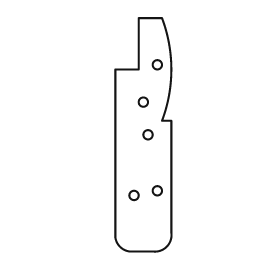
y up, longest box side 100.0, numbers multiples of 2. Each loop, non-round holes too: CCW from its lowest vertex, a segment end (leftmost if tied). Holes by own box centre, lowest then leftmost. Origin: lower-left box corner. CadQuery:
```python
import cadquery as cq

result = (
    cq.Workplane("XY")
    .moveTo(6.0, 0.0)
    .lineTo(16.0, 0.0)
    .threePointArc((22.0, 2.0), (24.0, 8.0))
    .lineTo(24.0, 56.0)
    .lineTo(20.0, 56.0)
    .threePointArc((24.0, 78.0), (20.0, 100.0))
    .lineTo(10.0, 100.0)
    .lineTo(10.0, 78.0)
    .lineTo(0.0, 78.0)
    .lineTo(0.0, 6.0)
    .threePointArc((2.0, 2.0), (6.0, 0.0))
    .close()
    .moveTo(8.0, 24.0)
    .circle(2.0)
    .moveTo(18.0, 26.0)
    .circle(2.0)
    .moveTo(14.0, 50.0)
    .circle(2.0)
    .moveTo(12.0, 64.0)
    .circle(2.0)
    .moveTo(18.0, 80.0)
    .circle(2.0)
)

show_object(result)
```